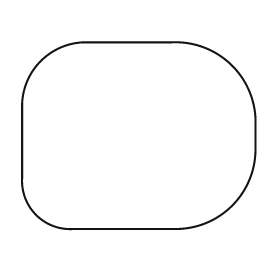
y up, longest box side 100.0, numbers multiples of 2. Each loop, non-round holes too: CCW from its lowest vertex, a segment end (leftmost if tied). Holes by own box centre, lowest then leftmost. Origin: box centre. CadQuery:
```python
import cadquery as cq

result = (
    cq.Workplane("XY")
    .moveTo(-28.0, -40.0)
    .lineTo(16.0, -40.0)
    .threePointArc((40.0, -30.0), (50.0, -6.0))
    .lineTo(50.0, 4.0)
    .threePointArc((40.0, 30.0), (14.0, 40.0))
    .lineTo(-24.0, 40.0)
    .threePointArc((-42.0, 32.0), (-50.0, 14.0))
    .lineTo(-50.0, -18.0)
    .threePointArc((-44.0, -34.0), (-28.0, -40.0))
    .close()
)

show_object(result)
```